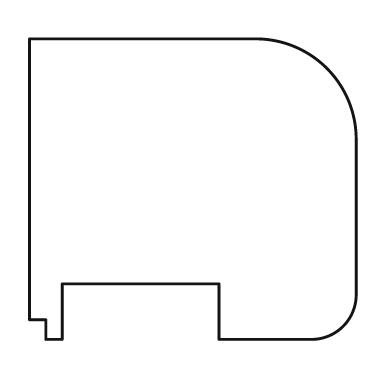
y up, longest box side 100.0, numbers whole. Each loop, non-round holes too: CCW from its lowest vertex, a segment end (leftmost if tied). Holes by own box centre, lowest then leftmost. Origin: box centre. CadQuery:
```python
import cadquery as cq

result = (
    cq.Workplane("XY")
    .moveTo(-45.0, -46.0)
    .lineTo(-40.0, -46.0)
    .lineTo(-40.0, -29.0)
    .lineTo(8.0, -29.0)
    .lineTo(8.0, -46.0)
    .lineTo(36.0, -46.0)
    .threePointArc((46.0, -42.0), (50.0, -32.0))
    .lineTo(50.0, 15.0)
    .threePointArc((41.0, 37.0), (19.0, 46.0))
    .lineTo(-50.0, 46.0)
    .lineTo(-50.0, -40.0)
    .lineTo(-45.0, -40.0)
    .close()
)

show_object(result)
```